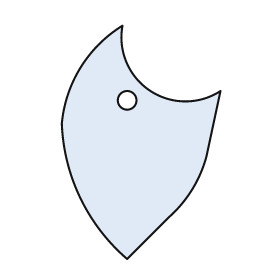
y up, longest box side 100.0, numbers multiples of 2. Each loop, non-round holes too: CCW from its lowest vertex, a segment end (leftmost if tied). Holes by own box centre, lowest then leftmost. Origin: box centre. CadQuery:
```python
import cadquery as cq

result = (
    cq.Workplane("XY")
    .moveTo(-6.0, -50.0)
    .lineTo(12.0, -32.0)
    .threePointArc((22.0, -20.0), (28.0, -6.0))
    .lineTo(34.0, 22.0)
    .threePointArc((4.0, 22.0), (-8.0, 50.0))
    .threePointArc((-26.0, 32.0), (-34.0, 8.0))
    .threePointArc((-26.0, -24.0), (-6.0, -50.0))
    .close()
    .moveTo(-6.0, 18.0)
    .circle(4.0)
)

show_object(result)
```